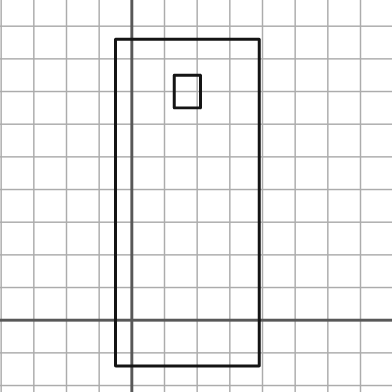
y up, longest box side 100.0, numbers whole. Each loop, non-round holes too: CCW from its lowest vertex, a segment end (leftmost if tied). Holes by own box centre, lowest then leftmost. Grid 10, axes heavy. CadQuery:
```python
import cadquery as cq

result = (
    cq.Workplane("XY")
    .moveTo(-5.0, -14.0)
    .lineTo(39.0, -14.0)
    .lineTo(39.0, 86.0)
    .lineTo(-5.0, 86.0)
    .close()
    .moveTo(13.0, 65.0)
    .lineTo(21.0, 65.0)
    .lineTo(21.0, 75.0)
    .lineTo(13.0, 75.0)
    .close()
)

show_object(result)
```